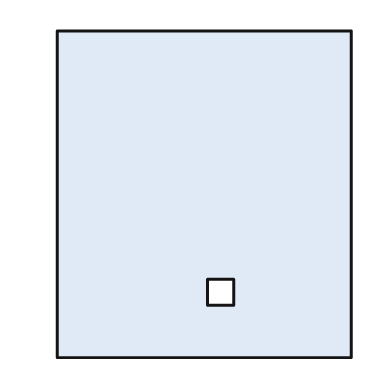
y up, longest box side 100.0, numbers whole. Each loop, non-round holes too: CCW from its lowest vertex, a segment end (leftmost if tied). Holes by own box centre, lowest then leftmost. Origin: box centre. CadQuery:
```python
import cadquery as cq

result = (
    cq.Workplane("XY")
    .moveTo(-45.0, -50.0)
    .lineTo(45.0, -50.0)
    .lineTo(45.0, 50.0)
    .lineTo(-45.0, 50.0)
    .close()
    .moveTo(1.0, -34.0)
    .lineTo(9.0, -34.0)
    .lineTo(9.0, -26.0)
    .lineTo(1.0, -26.0)
    .close()
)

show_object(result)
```